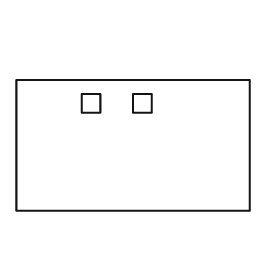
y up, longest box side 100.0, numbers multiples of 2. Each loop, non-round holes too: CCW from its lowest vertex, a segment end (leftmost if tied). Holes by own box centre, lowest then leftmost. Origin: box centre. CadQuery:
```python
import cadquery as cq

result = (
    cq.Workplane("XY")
    .moveTo(-50.0, -28.0)
    .lineTo(50.0, -28.0)
    .lineTo(50.0, 28.0)
    .lineTo(-50.0, 28.0)
    .close()
    .moveTo(-22.0, 14.0)
    .lineTo(-14.0, 14.0)
    .lineTo(-14.0, 22.0)
    .lineTo(-22.0, 22.0)
    .close()
    .moveTo(0.0, 14.0)
    .lineTo(8.0, 14.0)
    .lineTo(8.0, 22.0)
    .lineTo(0.0, 22.0)
    .close()
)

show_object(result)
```